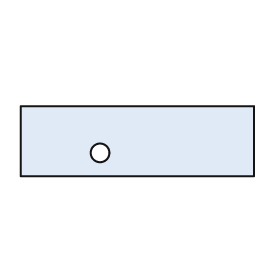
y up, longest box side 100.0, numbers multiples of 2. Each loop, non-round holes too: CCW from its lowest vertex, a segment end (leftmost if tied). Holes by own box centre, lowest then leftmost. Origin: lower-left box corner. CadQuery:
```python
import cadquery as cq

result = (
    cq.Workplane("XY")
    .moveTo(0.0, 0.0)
    .lineTo(100.0, 0.0)
    .lineTo(100.0, 30.0)
    .lineTo(0.0, 30.0)
    .close()
    .moveTo(34.0, 10.0)
    .circle(4.0)
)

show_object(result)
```